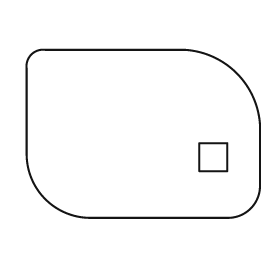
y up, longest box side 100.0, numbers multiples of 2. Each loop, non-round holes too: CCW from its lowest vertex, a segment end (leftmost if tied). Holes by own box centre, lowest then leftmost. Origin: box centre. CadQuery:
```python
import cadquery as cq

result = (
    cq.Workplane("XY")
    .moveTo(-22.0, -36.0)
    .lineTo(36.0, -36.0)
    .threePointArc((46.0, -32.0), (50.0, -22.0))
    .lineTo(50.0, 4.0)
    .threePointArc((40.0, 26.0), (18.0, 36.0))
    .lineTo(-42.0, 36.0)
    .threePointArc((-48.0, 34.0), (-50.0, 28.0))
    .lineTo(-50.0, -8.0)
    .threePointArc((-42.0, -28.0), (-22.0, -36.0))
    .close()
    .moveTo(24.0, -16.0)
    .lineTo(36.0, -16.0)
    .lineTo(36.0, -4.0)
    .lineTo(24.0, -4.0)
    .close()
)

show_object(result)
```